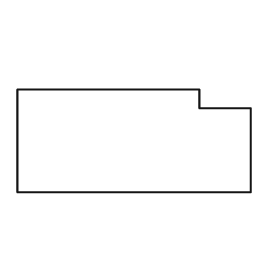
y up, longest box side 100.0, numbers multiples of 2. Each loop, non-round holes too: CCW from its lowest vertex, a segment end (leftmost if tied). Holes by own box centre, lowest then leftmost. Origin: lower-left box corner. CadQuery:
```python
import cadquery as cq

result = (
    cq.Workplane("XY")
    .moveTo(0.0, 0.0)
    .lineTo(100.0, 0.0)
    .lineTo(100.0, 36.0)
    .lineTo(78.0, 36.0)
    .lineTo(78.0, 44.0)
    .lineTo(0.0, 44.0)
    .close()
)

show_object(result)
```